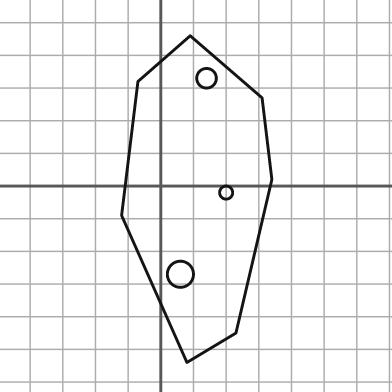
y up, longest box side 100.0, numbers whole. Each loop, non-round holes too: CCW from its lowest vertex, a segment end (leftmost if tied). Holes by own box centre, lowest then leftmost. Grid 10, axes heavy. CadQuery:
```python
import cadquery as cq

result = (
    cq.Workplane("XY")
    .moveTo(8.0, -54.0)
    .lineTo(23.0, -45.0)
    .lineTo(34.0, 2.0)
    .lineTo(31.0, 27.0)
    .lineTo(9.0, 46.0)
    .lineTo(-7.0, 32.0)
    .lineTo(-12.0, -9.0)
    .close()
    .moveTo(6.0, -27.0)
    .circle(4.0)
    .moveTo(20.0, -2.0)
    .circle(2.0)
    .moveTo(14.0, 33.0)
    .circle(3.0)
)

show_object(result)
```